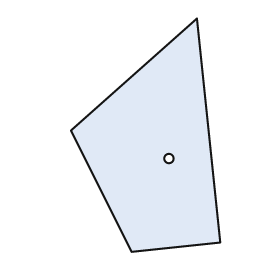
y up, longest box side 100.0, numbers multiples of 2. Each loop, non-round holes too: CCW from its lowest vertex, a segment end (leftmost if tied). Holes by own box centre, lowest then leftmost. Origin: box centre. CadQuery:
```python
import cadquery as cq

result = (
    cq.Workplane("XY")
    .moveTo(-6.0, -50.0)
    .lineTo(32.0, -46.0)
    .lineTo(22.0, 50.0)
    .lineTo(-32.0, 2.0)
    .close()
    .moveTo(10.0, -10.0)
    .circle(2.0)
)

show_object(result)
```